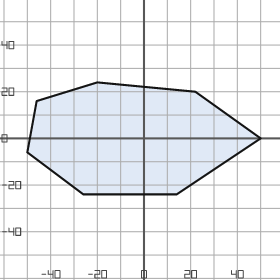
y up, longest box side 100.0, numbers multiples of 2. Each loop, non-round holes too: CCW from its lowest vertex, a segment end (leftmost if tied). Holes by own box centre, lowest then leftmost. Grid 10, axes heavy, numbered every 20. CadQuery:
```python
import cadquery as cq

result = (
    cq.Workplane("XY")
    .moveTo(-26.0, -24.0)
    .lineTo(14.0, -24.0)
    .lineTo(50.0, 0.0)
    .lineTo(22.0, 20.0)
    .lineTo(-20.0, 24.0)
    .lineTo(-46.0, 16.0)
    .lineTo(-50.0, -6.0)
    .close()
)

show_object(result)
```